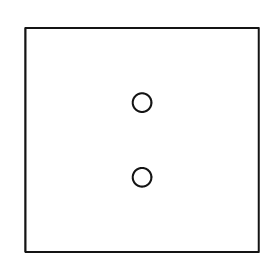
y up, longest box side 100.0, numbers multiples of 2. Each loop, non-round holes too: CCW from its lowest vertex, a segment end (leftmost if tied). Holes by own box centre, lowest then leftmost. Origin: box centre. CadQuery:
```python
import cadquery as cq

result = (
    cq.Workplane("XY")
    .moveTo(-50.0, -48.0)
    .lineTo(50.0, -48.0)
    .lineTo(50.0, 48.0)
    .lineTo(-50.0, 48.0)
    .close()
    .moveTo(0.0, -16.0)
    .circle(4.0)
    .moveTo(0.0, 16.0)
    .circle(4.0)
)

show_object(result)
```